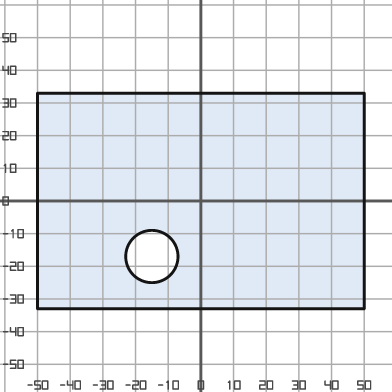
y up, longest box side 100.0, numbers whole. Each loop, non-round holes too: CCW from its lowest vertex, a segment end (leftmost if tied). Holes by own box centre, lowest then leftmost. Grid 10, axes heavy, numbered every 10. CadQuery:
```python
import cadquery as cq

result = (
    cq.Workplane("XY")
    .moveTo(-50.0, -33.0)
    .lineTo(50.0, -33.0)
    .lineTo(50.0, 33.0)
    .lineTo(-50.0, 33.0)
    .close()
    .moveTo(-15.0, -17.0)
    .circle(8.0)
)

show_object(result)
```